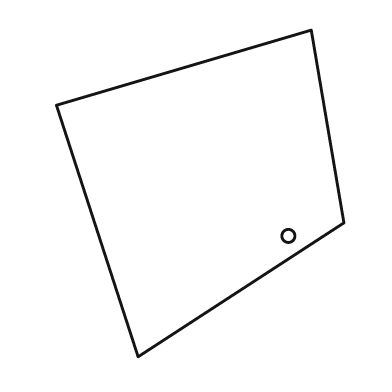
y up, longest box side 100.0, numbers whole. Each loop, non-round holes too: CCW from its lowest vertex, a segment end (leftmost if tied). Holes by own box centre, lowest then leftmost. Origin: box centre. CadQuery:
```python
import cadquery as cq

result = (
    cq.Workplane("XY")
    .moveTo(-19.0, -50.0)
    .lineTo(44.0, -9.0)
    .lineTo(34.0, 50.0)
    .lineTo(-44.0, 27.0)
    .close()
    .moveTo(27.0, -13.0)
    .circle(2.0)
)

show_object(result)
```